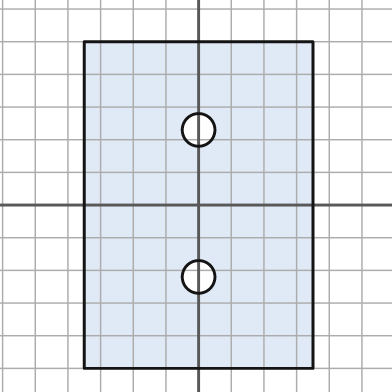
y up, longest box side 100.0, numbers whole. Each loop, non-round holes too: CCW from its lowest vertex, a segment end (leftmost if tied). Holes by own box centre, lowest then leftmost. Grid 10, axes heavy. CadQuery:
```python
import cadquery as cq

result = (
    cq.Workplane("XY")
    .moveTo(-35.0, -50.0)
    .lineTo(35.0, -50.0)
    .lineTo(35.0, 50.0)
    .lineTo(-35.0, 50.0)
    .close()
    .moveTo(0.0, -22.0)
    .circle(5.0)
    .moveTo(0.0, 23.0)
    .circle(5.0)
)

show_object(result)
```